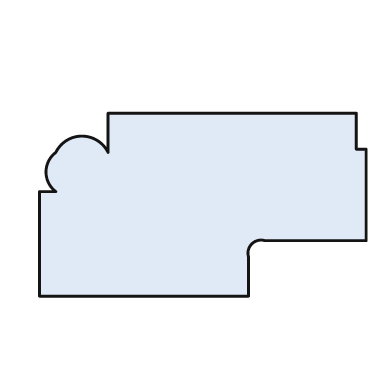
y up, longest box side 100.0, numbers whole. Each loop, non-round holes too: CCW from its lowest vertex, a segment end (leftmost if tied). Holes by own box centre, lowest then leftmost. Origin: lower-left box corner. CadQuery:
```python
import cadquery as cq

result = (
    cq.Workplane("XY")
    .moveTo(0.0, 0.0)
    .lineTo(64.0, 0.0)
    .lineTo(64.0, 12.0)
    .threePointArc((65.0, 16.0), (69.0, 17.0))
    .lineTo(100.0, 17.0)
    .lineTo(100.0, 45.0)
    .lineTo(97.0, 45.0)
    .lineTo(97.0, 56.0)
    .lineTo(21.0, 56.0)
    .lineTo(21.0, 44.0)
    .threePointArc((13.0, 49.0), (5.0, 44.0))
    .threePointArc((2.0, 38.0), (5.0, 32.0))
    .lineTo(0.0, 32.0)
    .close()
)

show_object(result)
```